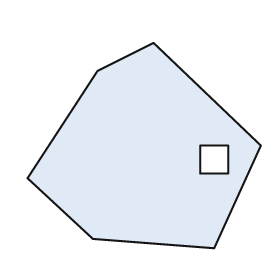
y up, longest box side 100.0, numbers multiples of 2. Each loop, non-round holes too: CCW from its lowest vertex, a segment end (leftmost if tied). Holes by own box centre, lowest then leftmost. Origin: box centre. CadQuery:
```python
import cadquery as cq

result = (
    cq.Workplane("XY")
    .moveTo(30.0, -44.0)
    .lineTo(50.0, 0.0)
    .lineTo(4.0, 44.0)
    .lineTo(-20.0, 32.0)
    .lineTo(-50.0, -14.0)
    .lineTo(-22.0, -40.0)
    .close()
    .moveTo(24.0, -12.0)
    .lineTo(36.0, -12.0)
    .lineTo(36.0, 0.0)
    .lineTo(24.0, 0.0)
    .close()
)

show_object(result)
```